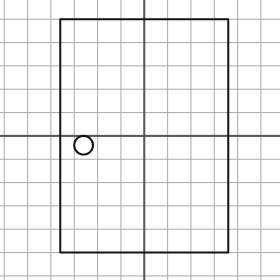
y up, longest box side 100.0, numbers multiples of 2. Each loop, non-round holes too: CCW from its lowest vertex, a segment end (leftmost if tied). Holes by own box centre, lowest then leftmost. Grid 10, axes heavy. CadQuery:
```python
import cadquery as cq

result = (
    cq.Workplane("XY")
    .moveTo(-36.0, -50.0)
    .lineTo(36.0, -50.0)
    .lineTo(36.0, 50.0)
    .lineTo(-36.0, 50.0)
    .close()
    .moveTo(-26.0, -4.0)
    .circle(4.0)
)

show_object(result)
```